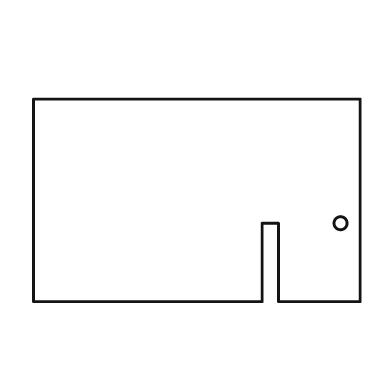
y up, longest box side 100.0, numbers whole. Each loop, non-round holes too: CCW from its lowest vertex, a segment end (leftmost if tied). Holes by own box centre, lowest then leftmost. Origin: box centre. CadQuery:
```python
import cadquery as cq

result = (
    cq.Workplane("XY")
    .moveTo(-50.0, -31.0)
    .lineTo(20.0, -31.0)
    .lineTo(20.0, -7.0)
    .lineTo(25.0, -7.0)
    .lineTo(25.0, -31.0)
    .lineTo(50.0, -31.0)
    .lineTo(50.0, 31.0)
    .lineTo(-50.0, 31.0)
    .close()
    .moveTo(44.0, -7.0)
    .circle(2.0)
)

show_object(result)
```